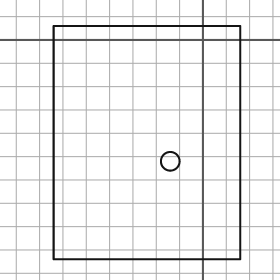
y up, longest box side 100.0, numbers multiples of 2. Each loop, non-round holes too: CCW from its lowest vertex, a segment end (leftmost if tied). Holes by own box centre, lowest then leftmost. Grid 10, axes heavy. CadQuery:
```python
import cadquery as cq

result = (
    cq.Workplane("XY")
    .moveTo(-64.0, -94.0)
    .lineTo(16.0, -94.0)
    .lineTo(16.0, 6.0)
    .lineTo(-64.0, 6.0)
    .close()
    .moveTo(-14.0, -52.0)
    .circle(4.0)
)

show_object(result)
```